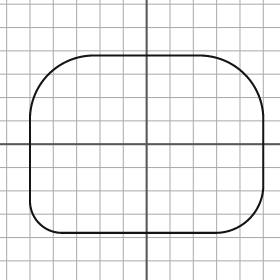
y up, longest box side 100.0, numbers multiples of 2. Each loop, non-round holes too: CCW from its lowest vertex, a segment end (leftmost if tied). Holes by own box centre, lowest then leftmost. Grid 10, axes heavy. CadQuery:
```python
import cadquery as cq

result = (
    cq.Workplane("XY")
    .moveTo(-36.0, -38.0)
    .lineTo(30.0, -38.0)
    .threePointArc((44.0, -32.0), (50.0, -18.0))
    .lineTo(50.0, 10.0)
    .threePointArc((42.0, 30.0), (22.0, 38.0))
    .lineTo(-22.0, 38.0)
    .threePointArc((-42.0, 30.0), (-50.0, 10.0))
    .lineTo(-50.0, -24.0)
    .threePointArc((-46.0, -34.0), (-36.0, -38.0))
    .close()
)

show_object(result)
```